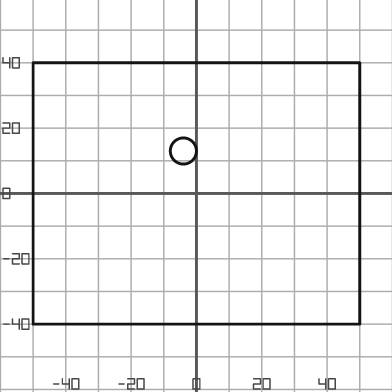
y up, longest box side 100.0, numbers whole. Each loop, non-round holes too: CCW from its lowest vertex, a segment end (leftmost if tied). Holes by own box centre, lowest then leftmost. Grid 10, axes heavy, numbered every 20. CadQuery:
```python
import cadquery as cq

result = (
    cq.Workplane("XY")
    .moveTo(-50.0, -40.0)
    .lineTo(50.0, -40.0)
    .lineTo(50.0, 40.0)
    .lineTo(-50.0, 40.0)
    .close()
    .moveTo(-4.0, 13.0)
    .circle(4.0)
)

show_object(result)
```